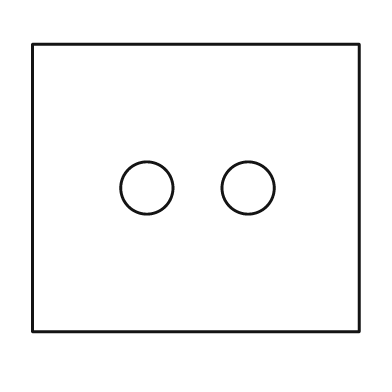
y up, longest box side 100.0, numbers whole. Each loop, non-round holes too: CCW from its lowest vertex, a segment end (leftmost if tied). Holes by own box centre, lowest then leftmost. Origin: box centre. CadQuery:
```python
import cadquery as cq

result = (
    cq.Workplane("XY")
    .moveTo(-50.0, -44.0)
    .lineTo(50.0, -44.0)
    .lineTo(50.0, 44.0)
    .lineTo(-50.0, 44.0)
    .close()
    .moveTo(-15.0, 0.0)
    .circle(8.0)
    .moveTo(16.0, 0.0)
    .circle(8.0)
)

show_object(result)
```